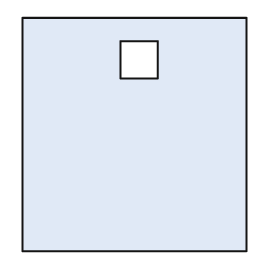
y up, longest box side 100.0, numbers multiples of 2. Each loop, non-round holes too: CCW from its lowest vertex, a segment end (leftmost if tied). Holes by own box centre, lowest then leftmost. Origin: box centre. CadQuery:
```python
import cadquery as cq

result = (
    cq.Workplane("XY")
    .moveTo(-48.0, -50.0)
    .lineTo(48.0, -50.0)
    .lineTo(48.0, 50.0)
    .lineTo(-48.0, 50.0)
    .close()
    .moveTo(-6.0, 24.0)
    .lineTo(10.0, 24.0)
    .lineTo(10.0, 40.0)
    .lineTo(-6.0, 40.0)
    .close()
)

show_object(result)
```